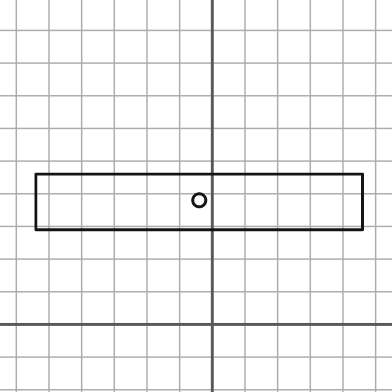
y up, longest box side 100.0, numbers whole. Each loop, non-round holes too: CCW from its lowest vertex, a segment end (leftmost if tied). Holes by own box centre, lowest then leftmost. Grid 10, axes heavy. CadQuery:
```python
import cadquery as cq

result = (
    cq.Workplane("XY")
    .moveTo(-54.0, 29.0)
    .lineTo(46.0, 29.0)
    .lineTo(46.0, 46.0)
    .lineTo(-54.0, 46.0)
    .close()
    .moveTo(-4.0, 38.0)
    .circle(2.0)
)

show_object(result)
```